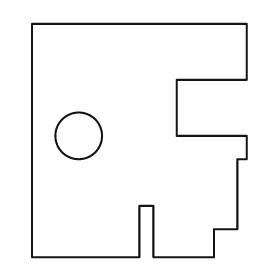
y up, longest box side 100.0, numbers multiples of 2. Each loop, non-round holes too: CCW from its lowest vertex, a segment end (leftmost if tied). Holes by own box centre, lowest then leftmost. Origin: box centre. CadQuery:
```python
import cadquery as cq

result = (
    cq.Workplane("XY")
    .moveTo(-46.0, -50.0)
    .lineTo(0.0, -50.0)
    .lineTo(0.0, -28.0)
    .lineTo(6.0, -28.0)
    .lineTo(6.0, -50.0)
    .lineTo(32.0, -50.0)
    .lineTo(32.0, -38.0)
    .lineTo(42.0, -38.0)
    .lineTo(42.0, -8.0)
    .lineTo(46.0, -8.0)
    .lineTo(46.0, 2.0)
    .lineTo(16.0, 2.0)
    .lineTo(16.0, 26.0)
    .lineTo(46.0, 26.0)
    .lineTo(46.0, 50.0)
    .lineTo(-46.0, 50.0)
    .close()
    .moveTo(-26.0, 2.0)
    .circle(10.0)
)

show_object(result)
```